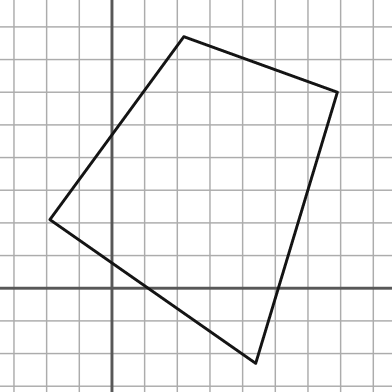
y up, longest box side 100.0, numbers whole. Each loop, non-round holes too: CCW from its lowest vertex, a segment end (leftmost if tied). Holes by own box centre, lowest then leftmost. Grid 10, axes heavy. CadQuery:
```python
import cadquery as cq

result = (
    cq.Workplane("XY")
    .moveTo(44.0, -23.0)
    .lineTo(69.0, 60.0)
    .lineTo(22.0, 77.0)
    .lineTo(-19.0, 21.0)
    .close()
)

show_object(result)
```